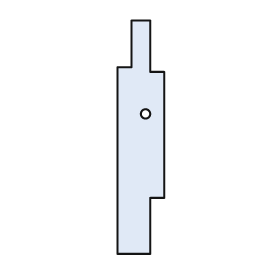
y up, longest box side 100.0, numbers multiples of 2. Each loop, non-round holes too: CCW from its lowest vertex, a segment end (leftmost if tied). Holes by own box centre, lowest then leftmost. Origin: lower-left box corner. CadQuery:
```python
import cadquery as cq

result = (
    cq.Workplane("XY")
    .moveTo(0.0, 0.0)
    .lineTo(14.0, 0.0)
    .lineTo(14.0, 24.0)
    .lineTo(20.0, 24.0)
    .lineTo(20.0, 78.0)
    .lineTo(14.0, 78.0)
    .lineTo(14.0, 100.0)
    .lineTo(6.0, 100.0)
    .lineTo(6.0, 80.0)
    .lineTo(0.0, 80.0)
    .close()
    .moveTo(12.0, 60.0)
    .circle(2.0)
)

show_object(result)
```